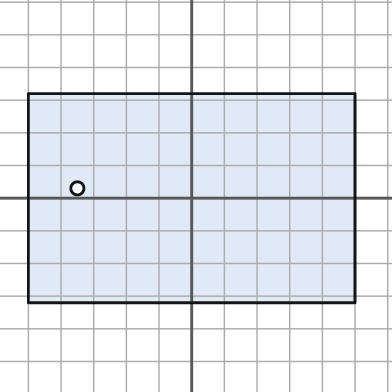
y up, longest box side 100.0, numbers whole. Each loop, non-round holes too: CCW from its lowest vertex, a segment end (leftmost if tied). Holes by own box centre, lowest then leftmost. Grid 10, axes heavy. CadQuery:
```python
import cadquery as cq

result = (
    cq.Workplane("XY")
    .moveTo(-50.0, -32.0)
    .lineTo(50.0, -32.0)
    .lineTo(50.0, 32.0)
    .lineTo(-50.0, 32.0)
    .close()
    .moveTo(-35.0, 3.0)
    .circle(2.0)
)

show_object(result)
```